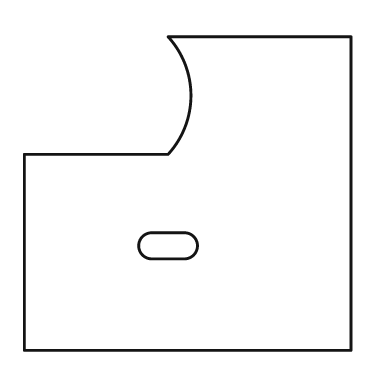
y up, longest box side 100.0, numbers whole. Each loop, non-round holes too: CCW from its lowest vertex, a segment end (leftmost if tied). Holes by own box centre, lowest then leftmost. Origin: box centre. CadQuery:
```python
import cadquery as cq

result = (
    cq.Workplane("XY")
    .moveTo(-50.0, -48.0)
    .lineTo(50.0, -48.0)
    .lineTo(50.0, 48.0)
    .lineTo(-6.0, 48.0)
    .threePointArc((1.0, 30.0), (-6.0, 12.0))
    .lineTo(-50.0, 12.0)
    .close()
    .moveTo(-11.0, -20.0)
    .lineTo(-1.0, -20.0)
    .threePointArc((3.0, -16.0), (-1.0, -12.0))
    .lineTo(-11.0, -12.0)
    .threePointArc((-15.0, -16.0), (-11.0, -20.0))
    .close()
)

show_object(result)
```